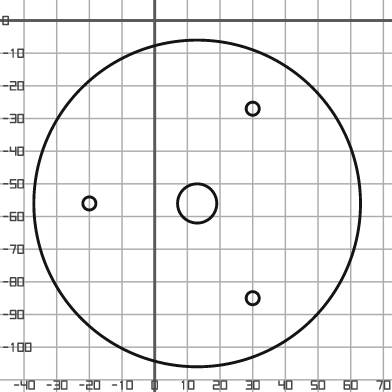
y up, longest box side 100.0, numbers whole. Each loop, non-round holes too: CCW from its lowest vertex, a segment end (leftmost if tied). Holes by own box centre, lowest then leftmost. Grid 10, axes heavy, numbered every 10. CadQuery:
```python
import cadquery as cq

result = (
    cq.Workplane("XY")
    .moveTo(13.0, -56.0)
    .circle(50.0)
    .moveTo(30.0, -85.0)
    .circle(2.0)
    .moveTo(-20.0, -56.0)
    .circle(2.0)
    .moveTo(13.0, -56.0)
    .circle(6.0)
    .moveTo(30.0, -27.0)
    .circle(2.0)
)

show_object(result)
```